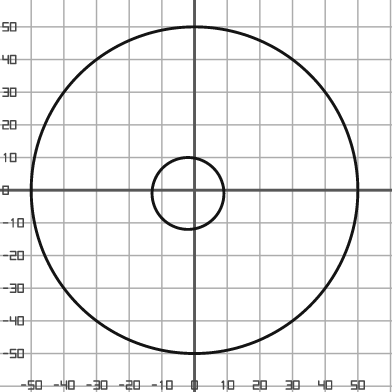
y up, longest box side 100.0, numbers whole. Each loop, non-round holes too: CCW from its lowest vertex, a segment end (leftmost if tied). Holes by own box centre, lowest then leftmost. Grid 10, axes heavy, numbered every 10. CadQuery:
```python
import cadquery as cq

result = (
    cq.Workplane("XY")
    .moveTo(0.0, 0.0)
    .circle(50.0)
    .moveTo(-2.0, -1.0)
    .circle(11.0)
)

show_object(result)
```